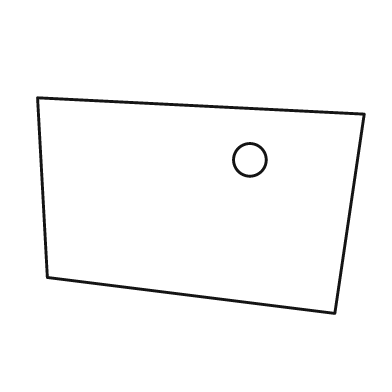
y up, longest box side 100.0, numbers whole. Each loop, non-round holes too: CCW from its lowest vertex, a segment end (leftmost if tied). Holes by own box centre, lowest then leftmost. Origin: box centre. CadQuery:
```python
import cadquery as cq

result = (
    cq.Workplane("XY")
    .moveTo(41.0, -33.0)
    .lineTo(50.0, 28.0)
    .lineTo(-50.0, 33.0)
    .lineTo(-47.0, -22.0)
    .close()
    .moveTo(15.0, 14.0)
    .circle(5.0)
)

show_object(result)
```